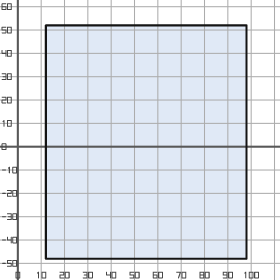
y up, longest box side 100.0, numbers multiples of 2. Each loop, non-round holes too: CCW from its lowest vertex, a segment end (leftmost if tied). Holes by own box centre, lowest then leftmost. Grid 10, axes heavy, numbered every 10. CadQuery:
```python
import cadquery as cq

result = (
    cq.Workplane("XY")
    .moveTo(12.0, -48.0)
    .lineTo(98.0, -48.0)
    .lineTo(98.0, 52.0)
    .lineTo(12.0, 52.0)
    .close()
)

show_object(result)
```